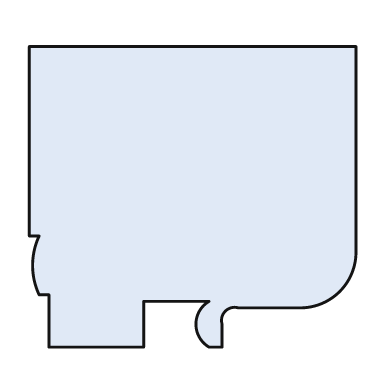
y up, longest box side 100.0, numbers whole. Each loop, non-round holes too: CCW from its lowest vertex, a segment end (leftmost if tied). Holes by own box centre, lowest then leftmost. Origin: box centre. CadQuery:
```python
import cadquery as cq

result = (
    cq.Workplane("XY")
    .moveTo(-44.0, -46.0)
    .lineTo(-15.0, -46.0)
    .lineTo(-15.0, -32.0)
    .lineTo(5.0, -32.0)
    .threePointArc((1.0, -39.0), (5.0, -46.0))
    .lineTo(9.0, -46.0)
    .lineTo(9.0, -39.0)
    .threePointArc((10.0, -35.0), (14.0, -34.0))
    .lineTo(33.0, -34.0)
    .threePointArc((45.0, -29.0), (50.0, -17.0))
    .lineTo(50.0, 46.0)
    .lineTo(-50.0, 46.0)
    .lineTo(-50.0, -12.0)
    .lineTo(-47.0, -12.0)
    .threePointArc((-49.0, -21.0), (-47.0, -30.0))
    .lineTo(-44.0, -30.0)
    .close()
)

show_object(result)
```